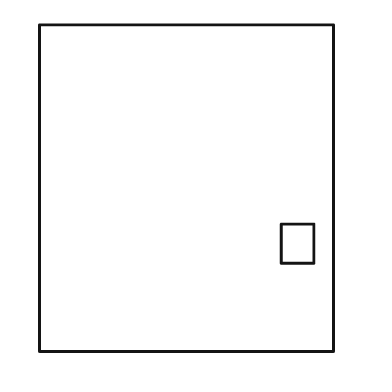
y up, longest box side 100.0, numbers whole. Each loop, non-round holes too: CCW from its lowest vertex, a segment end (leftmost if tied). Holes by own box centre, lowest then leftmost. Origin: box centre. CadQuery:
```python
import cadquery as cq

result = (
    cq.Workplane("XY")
    .moveTo(-45.0, -50.0)
    .lineTo(45.0, -50.0)
    .lineTo(45.0, 50.0)
    .lineTo(-45.0, 50.0)
    .close()
    .moveTo(29.0, -23.0)
    .lineTo(39.0, -23.0)
    .lineTo(39.0, -11.0)
    .lineTo(29.0, -11.0)
    .close()
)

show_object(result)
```